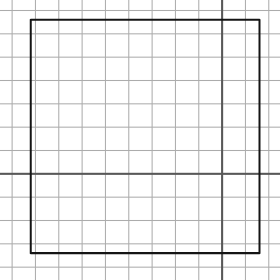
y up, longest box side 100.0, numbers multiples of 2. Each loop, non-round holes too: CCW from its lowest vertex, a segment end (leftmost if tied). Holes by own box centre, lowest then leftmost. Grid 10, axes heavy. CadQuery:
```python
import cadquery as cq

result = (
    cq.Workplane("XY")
    .moveTo(-82.0, -34.0)
    .lineTo(16.0, -34.0)
    .lineTo(16.0, 66.0)
    .lineTo(-82.0, 66.0)
    .close()
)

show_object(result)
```